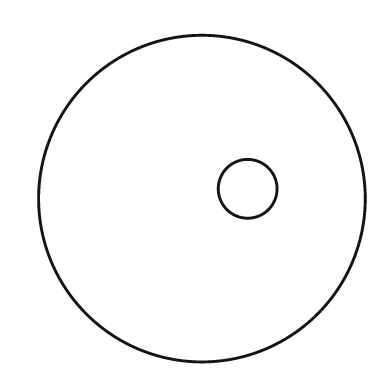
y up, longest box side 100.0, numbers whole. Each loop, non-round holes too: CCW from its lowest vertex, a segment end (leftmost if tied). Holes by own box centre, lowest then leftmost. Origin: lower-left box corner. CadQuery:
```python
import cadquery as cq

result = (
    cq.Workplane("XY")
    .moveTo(50.0, 50.0)
    .circle(50.0)
    .moveTo(64.0, 53.0)
    .circle(9.0)
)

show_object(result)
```